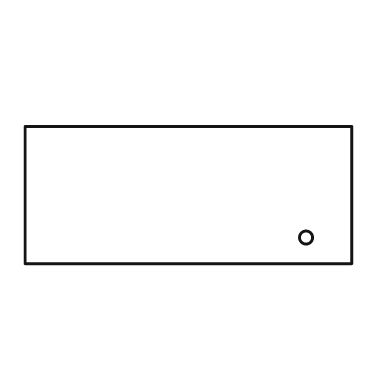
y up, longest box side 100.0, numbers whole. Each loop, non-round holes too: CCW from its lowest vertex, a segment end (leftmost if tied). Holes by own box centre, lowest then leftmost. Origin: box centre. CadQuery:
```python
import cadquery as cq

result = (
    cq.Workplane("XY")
    .moveTo(-50.0, -21.0)
    .lineTo(50.0, -21.0)
    .lineTo(50.0, 21.0)
    .lineTo(-50.0, 21.0)
    .close()
    .moveTo(36.0, -13.0)
    .circle(2.0)
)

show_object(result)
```